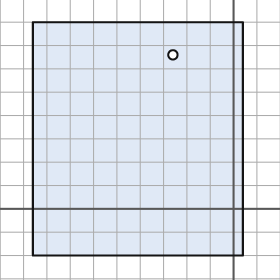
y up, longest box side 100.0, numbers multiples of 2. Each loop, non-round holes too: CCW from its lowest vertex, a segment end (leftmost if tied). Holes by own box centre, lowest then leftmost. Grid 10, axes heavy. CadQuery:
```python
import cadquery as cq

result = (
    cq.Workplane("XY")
    .moveTo(-86.0, -20.0)
    .lineTo(4.0, -20.0)
    .lineTo(4.0, 80.0)
    .lineTo(-86.0, 80.0)
    .close()
    .moveTo(-26.0, 66.0)
    .circle(2.0)
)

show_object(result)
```